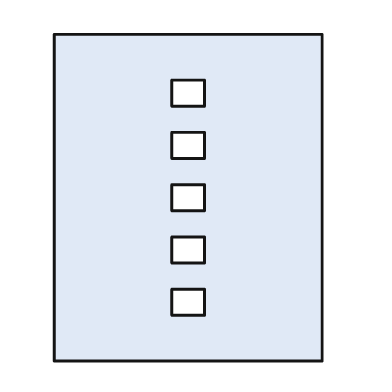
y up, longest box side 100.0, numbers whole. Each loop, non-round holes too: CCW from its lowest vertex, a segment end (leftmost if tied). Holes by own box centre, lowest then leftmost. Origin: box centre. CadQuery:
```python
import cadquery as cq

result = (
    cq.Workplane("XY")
    .moveTo(-41.0, -50.0)
    .lineTo(41.0, -50.0)
    .lineTo(41.0, 50.0)
    .lineTo(-41.0, 50.0)
    .close()
    .moveTo(-5.0, -36.0)
    .lineTo(5.0, -36.0)
    .lineTo(5.0, -28.0)
    .lineTo(-5.0, -28.0)
    .close()
    .moveTo(-5.0, -20.0)
    .lineTo(5.0, -20.0)
    .lineTo(5.0, -12.0)
    .lineTo(-5.0, -12.0)
    .close()
    .moveTo(-5.0, -4.0)
    .lineTo(5.0, -4.0)
    .lineTo(5.0, 4.0)
    .lineTo(-5.0, 4.0)
    .close()
    .moveTo(-5.0, 12.0)
    .lineTo(5.0, 12.0)
    .lineTo(5.0, 20.0)
    .lineTo(-5.0, 20.0)
    .close()
    .moveTo(-5.0, 28.0)
    .lineTo(5.0, 28.0)
    .lineTo(5.0, 36.0)
    .lineTo(-5.0, 36.0)
    .close()
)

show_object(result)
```